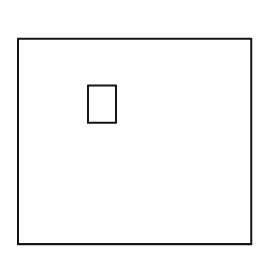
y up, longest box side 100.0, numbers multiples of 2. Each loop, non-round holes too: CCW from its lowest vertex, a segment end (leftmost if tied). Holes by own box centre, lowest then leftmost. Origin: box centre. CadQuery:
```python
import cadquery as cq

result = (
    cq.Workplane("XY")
    .moveTo(-50.0, -44.0)
    .lineTo(50.0, -44.0)
    .lineTo(50.0, 44.0)
    .lineTo(-50.0, 44.0)
    .close()
    .moveTo(-20.0, 8.0)
    .lineTo(-8.0, 8.0)
    .lineTo(-8.0, 24.0)
    .lineTo(-20.0, 24.0)
    .close()
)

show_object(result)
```